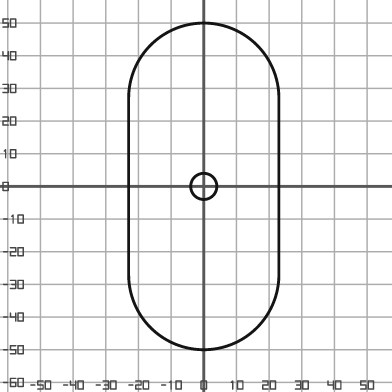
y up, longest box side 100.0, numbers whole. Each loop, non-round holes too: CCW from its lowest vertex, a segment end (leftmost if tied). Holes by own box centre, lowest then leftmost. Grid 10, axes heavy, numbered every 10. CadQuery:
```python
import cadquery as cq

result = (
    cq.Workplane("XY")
    .moveTo(-23.0, -27.0)
    .threePointArc((0.0, -50.0), (23.0, -27.0))
    .lineTo(23.0, 27.0)
    .threePointArc((0.0, 50.0), (-23.0, 27.0))
    .close()
    .moveTo(0.0, 0.0)
    .circle(4.0)
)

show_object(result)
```